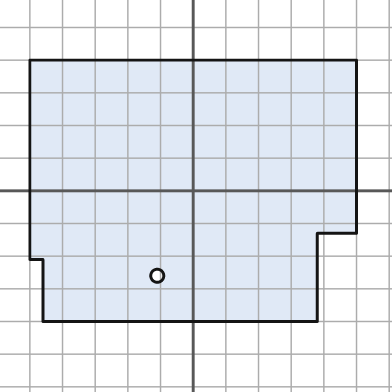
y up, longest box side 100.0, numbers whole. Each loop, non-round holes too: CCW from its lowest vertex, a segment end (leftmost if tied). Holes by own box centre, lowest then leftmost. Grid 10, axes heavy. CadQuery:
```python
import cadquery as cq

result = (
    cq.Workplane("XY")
    .moveTo(-46.0, -40.0)
    .lineTo(38.0, -40.0)
    .lineTo(38.0, -13.0)
    .lineTo(50.0, -13.0)
    .lineTo(50.0, 40.0)
    .lineTo(-50.0, 40.0)
    .lineTo(-50.0, -21.0)
    .lineTo(-46.0, -21.0)
    .close()
    .moveTo(-11.0, -26.0)
    .circle(2.0)
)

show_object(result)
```